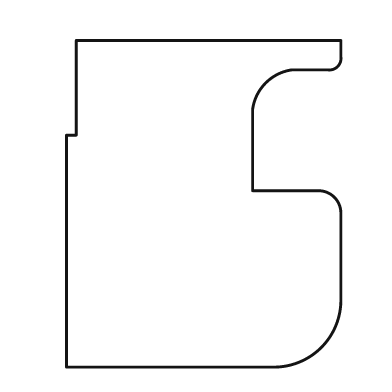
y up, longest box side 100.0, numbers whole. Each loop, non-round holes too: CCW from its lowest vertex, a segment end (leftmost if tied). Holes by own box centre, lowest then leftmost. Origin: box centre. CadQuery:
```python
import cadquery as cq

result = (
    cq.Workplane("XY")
    .moveTo(-42.0, -50.0)
    .lineTo(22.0, -50.0)
    .threePointArc((36.0, -44.0), (42.0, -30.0))
    .lineTo(42.0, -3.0)
    .threePointArc((40.0, 2.0), (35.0, 4.0))
    .lineTo(15.0, 4.0)
    .lineTo(15.0, 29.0)
    .threePointArc((19.0, 37.0), (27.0, 41.0))
    .lineTo(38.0, 41.0)
    .threePointArc((41.0, 42.0), (42.0, 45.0))
    .lineTo(42.0, 50.0)
    .lineTo(-39.0, 50.0)
    .lineTo(-39.0, 21.0)
    .lineTo(-42.0, 21.0)
    .close()
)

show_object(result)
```